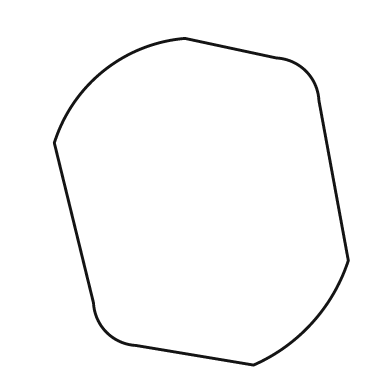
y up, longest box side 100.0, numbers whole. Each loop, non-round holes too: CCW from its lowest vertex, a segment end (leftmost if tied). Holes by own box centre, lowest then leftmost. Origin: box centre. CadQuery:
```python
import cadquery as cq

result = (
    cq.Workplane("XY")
    .moveTo(16.0, -50.0)
    .threePointArc((34.0, -37.0), (45.0, -18.0))
    .lineTo(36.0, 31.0)
    .threePointArc((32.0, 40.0), (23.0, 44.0))
    .lineTo(-5.0, 50.0)
    .threePointArc((-30.0, 40.0), (-45.0, 18.0))
    .lineTo(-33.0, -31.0)
    .threePointArc((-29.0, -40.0), (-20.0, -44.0))
    .close()
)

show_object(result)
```